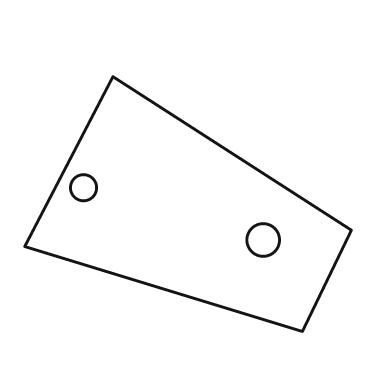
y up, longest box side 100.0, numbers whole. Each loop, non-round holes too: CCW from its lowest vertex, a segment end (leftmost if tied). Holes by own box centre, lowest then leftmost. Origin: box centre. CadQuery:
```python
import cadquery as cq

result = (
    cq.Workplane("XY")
    .moveTo(35.0, -39.0)
    .lineTo(50.0, -8.0)
    .lineTo(-23.0, 39.0)
    .lineTo(-50.0, -13.0)
    .close()
    .moveTo(23.0, -11.0)
    .circle(5.0)
    .moveTo(-32.0, 5.0)
    .circle(4.0)
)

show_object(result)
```